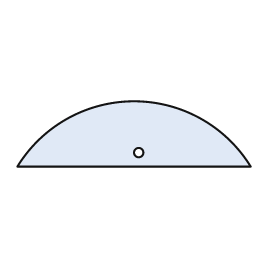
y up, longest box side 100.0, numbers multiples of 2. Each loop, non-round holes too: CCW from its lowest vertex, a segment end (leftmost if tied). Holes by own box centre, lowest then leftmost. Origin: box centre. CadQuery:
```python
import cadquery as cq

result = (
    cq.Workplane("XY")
    .moveTo(-50.0, -14.0)
    .lineTo(50.0, -14.0)
    .threePointArc((0.0, 14.0), (-50.0, -14.0))
    .close()
    .moveTo(2.0, -8.0)
    .circle(2.0)
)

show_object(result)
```